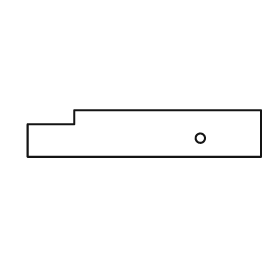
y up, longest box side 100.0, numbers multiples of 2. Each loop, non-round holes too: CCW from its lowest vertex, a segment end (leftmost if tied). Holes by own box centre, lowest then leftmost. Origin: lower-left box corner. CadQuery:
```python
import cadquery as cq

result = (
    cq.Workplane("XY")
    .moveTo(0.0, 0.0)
    .lineTo(100.0, 0.0)
    .lineTo(100.0, 20.0)
    .lineTo(20.0, 20.0)
    .lineTo(20.0, 14.0)
    .lineTo(0.0, 14.0)
    .close()
    .moveTo(74.0, 8.0)
    .circle(2.0)
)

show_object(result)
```